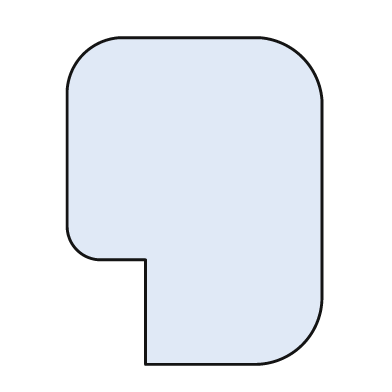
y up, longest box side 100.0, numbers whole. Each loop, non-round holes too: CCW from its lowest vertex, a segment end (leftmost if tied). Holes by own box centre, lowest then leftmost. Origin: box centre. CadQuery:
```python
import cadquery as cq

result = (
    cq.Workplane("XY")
    .moveTo(-15.0, -50.0)
    .lineTo(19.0, -50.0)
    .threePointArc((33.0, -44.0), (39.0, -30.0))
    .lineTo(39.0, 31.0)
    .threePointArc((33.0, 44.0), (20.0, 50.0))
    .lineTo(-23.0, 50.0)
    .threePointArc((-34.0, 45.0), (-39.0, 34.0))
    .lineTo(-39.0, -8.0)
    .threePointArc((-36.0, -15.0), (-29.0, -18.0))
    .lineTo(-15.0, -18.0)
    .close()
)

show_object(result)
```